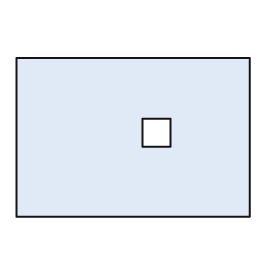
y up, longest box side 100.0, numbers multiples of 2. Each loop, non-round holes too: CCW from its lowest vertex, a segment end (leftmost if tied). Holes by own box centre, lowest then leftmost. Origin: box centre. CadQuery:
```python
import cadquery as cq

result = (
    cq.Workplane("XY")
    .moveTo(-50.0, -34.0)
    .lineTo(50.0, -34.0)
    .lineTo(50.0, 34.0)
    .lineTo(-50.0, 34.0)
    .close()
    .moveTo(4.0, -4.0)
    .lineTo(16.0, -4.0)
    .lineTo(16.0, 8.0)
    .lineTo(4.0, 8.0)
    .close()
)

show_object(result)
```